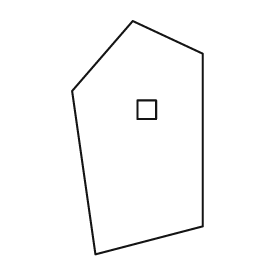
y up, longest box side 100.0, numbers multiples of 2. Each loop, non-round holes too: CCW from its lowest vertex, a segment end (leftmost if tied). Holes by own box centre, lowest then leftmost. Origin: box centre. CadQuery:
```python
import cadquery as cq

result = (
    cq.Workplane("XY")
    .moveTo(-18.0, -50.0)
    .lineTo(28.0, -38.0)
    .lineTo(28.0, 36.0)
    .lineTo(-2.0, 50.0)
    .lineTo(-28.0, 20.0)
    .close()
    .moveTo(0.0, 8.0)
    .lineTo(8.0, 8.0)
    .lineTo(8.0, 16.0)
    .lineTo(0.0, 16.0)
    .close()
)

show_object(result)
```